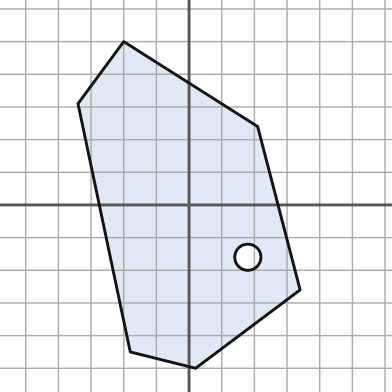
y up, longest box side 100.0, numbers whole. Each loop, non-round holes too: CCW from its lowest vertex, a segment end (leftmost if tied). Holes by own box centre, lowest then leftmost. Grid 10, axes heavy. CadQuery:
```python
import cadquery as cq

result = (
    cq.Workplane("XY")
    .moveTo(2.0, -50.0)
    .lineTo(34.0, -26.0)
    .lineTo(21.0, 24.0)
    .lineTo(-20.0, 50.0)
    .lineTo(-34.0, 31.0)
    .lineTo(-18.0, -45.0)
    .close()
    .moveTo(18.0, -16.0)
    .circle(4.0)
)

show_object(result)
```